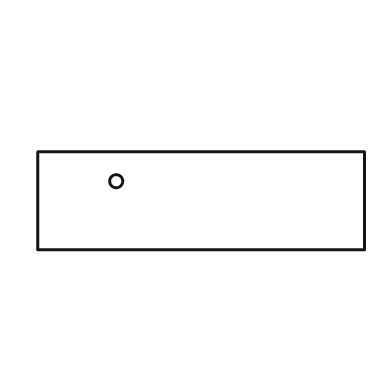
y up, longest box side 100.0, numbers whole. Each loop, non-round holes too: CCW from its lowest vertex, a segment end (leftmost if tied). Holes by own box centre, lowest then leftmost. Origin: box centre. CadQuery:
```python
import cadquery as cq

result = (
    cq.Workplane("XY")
    .moveTo(-50.0, -15.0)
    .lineTo(50.0, -15.0)
    .lineTo(50.0, 15.0)
    .lineTo(-50.0, 15.0)
    .close()
    .moveTo(-26.0, 6.0)
    .circle(2.0)
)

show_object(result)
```